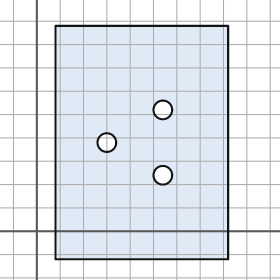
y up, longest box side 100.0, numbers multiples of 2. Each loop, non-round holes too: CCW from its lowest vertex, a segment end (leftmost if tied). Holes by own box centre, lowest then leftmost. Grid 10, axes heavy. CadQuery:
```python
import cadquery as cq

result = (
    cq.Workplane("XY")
    .moveTo(8.0, -12.0)
    .lineTo(82.0, -12.0)
    .lineTo(82.0, 88.0)
    .lineTo(8.0, 88.0)
    .close()
    .moveTo(54.0, 24.0)
    .circle(4.0)
    .moveTo(30.0, 38.0)
    .circle(4.0)
    .moveTo(54.0, 52.0)
    .circle(4.0)
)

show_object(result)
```